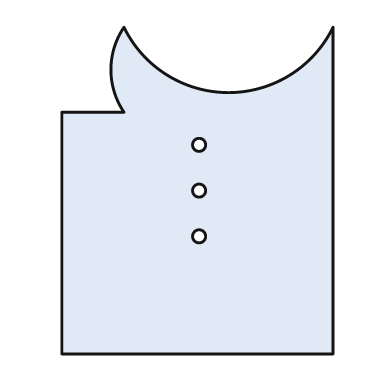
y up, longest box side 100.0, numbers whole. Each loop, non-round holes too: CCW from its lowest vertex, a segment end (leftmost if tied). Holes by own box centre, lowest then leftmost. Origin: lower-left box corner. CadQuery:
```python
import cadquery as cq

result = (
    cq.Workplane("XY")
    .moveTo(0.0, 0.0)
    .lineTo(83.0, 0.0)
    .lineTo(83.0, 100.0)
    .threePointArc((51.0, 80.0), (19.0, 100.0))
    .threePointArc((15.0, 87.0), (19.0, 74.0))
    .lineTo(0.0, 74.0)
    .close()
    .moveTo(42.0, 36.0)
    .circle(2.0)
    .moveTo(42.0, 50.0)
    .circle(2.0)
    .moveTo(42.0, 64.0)
    .circle(2.0)
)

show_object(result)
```